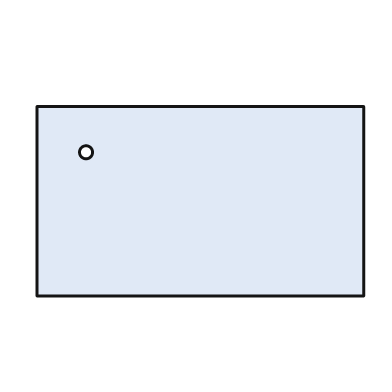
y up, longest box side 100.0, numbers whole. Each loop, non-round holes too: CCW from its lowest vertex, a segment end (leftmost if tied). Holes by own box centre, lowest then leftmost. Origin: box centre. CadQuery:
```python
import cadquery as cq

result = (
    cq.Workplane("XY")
    .moveTo(-50.0, -29.0)
    .lineTo(50.0, -29.0)
    .lineTo(50.0, 29.0)
    .lineTo(-50.0, 29.0)
    .close()
    .moveTo(-35.0, 15.0)
    .circle(2.0)
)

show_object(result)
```